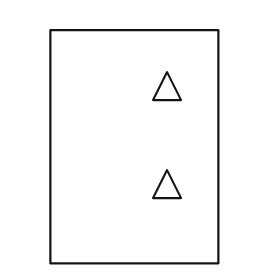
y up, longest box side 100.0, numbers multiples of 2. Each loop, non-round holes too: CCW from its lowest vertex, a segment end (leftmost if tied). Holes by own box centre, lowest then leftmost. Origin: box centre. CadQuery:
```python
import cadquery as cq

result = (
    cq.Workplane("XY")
    .moveTo(-36.0, -50.0)
    .lineTo(36.0, -50.0)
    .lineTo(36.0, 50.0)
    .lineTo(-36.0, 50.0)
    .close()
    .moveTo(8.0, -22.0)
    .lineTo(20.0, -22.0)
    .lineTo(14.0, -10.0)
    .close()
    .moveTo(8.0, 20.0)
    .lineTo(20.0, 20.0)
    .lineTo(14.0, 32.0)
    .close()
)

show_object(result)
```